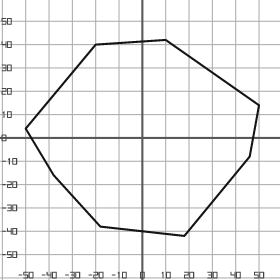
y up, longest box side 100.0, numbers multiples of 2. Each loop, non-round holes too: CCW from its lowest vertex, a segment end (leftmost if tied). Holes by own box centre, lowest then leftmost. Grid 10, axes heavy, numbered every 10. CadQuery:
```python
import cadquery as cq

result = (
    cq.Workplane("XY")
    .moveTo(18.0, -42.0)
    .lineTo(46.0, -8.0)
    .lineTo(50.0, 14.0)
    .lineTo(10.0, 42.0)
    .lineTo(-20.0, 40.0)
    .lineTo(-50.0, 4.0)
    .lineTo(-38.0, -16.0)
    .lineTo(-18.0, -38.0)
    .close()
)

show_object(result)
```